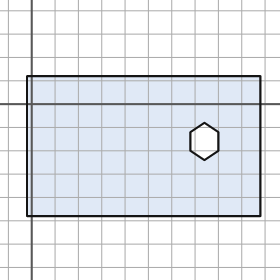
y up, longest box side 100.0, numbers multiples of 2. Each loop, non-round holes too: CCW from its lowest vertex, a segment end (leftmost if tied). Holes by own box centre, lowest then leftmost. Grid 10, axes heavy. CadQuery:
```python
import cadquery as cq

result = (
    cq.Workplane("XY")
    .moveTo(-2.0, -48.0)
    .lineTo(98.0, -48.0)
    .lineTo(98.0, 12.0)
    .lineTo(-2.0, 12.0)
    .close()
    .moveTo(74.0, -24.0)
    .lineTo(80.0, -20.0)
    .lineTo(80.0, -12.0)
    .lineTo(74.0, -8.0)
    .lineTo(68.0, -12.0)
    .lineTo(68.0, -20.0)
    .close()
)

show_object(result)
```